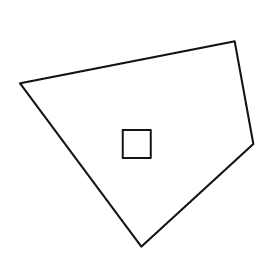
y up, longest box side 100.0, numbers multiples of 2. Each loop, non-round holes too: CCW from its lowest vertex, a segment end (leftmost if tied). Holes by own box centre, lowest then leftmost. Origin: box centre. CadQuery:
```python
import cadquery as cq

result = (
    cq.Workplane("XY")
    .moveTo(2.0, -44.0)
    .lineTo(50.0, 0.0)
    .lineTo(42.0, 44.0)
    .lineTo(-50.0, 26.0)
    .close()
    .moveTo(-6.0, -6.0)
    .lineTo(6.0, -6.0)
    .lineTo(6.0, 6.0)
    .lineTo(-6.0, 6.0)
    .close()
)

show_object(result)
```